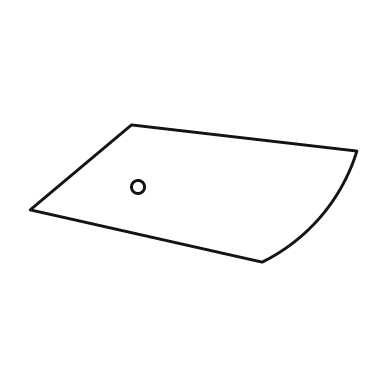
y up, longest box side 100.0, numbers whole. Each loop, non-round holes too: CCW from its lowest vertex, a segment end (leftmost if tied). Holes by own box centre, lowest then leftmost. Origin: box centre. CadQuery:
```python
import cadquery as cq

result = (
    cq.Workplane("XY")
    .moveTo(21.0, -21.0)
    .threePointArc((39.0, -7.0), (50.0, 13.0))
    .lineTo(-19.0, 21.0)
    .lineTo(-50.0, -5.0)
    .close()
    .moveTo(-17.0, 2.0)
    .circle(2.0)
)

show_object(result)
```